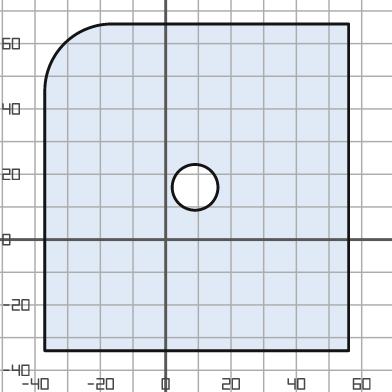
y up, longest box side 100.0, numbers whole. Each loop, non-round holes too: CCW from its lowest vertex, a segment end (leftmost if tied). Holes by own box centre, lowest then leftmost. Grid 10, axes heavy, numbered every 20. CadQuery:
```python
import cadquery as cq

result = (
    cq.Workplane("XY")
    .moveTo(-37.0, -34.0)
    .lineTo(56.0, -34.0)
    .lineTo(56.0, 66.0)
    .lineTo(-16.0, 66.0)
    .threePointArc((-31.0, 60.0), (-37.0, 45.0))
    .close()
    .moveTo(9.0, 16.0)
    .circle(7.0)
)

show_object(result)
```